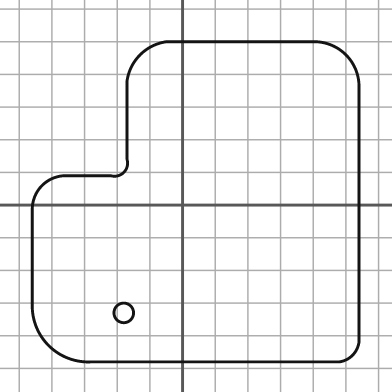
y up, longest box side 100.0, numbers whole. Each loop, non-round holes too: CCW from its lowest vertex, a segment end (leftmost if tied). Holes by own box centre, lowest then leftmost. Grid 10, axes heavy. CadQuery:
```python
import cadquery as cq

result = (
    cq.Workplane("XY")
    .moveTo(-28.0, -48.0)
    .lineTo(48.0, -48.0)
    .threePointArc((52.0, -46.0), (54.0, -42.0))
    .lineTo(54.0, 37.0)
    .threePointArc((50.0, 46.0), (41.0, 50.0))
    .lineTo(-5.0, 50.0)
    .threePointArc((-13.0, 46.0), (-17.0, 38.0))
    .lineTo(-17.0, 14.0)
    .threePointArc((-18.0, 10.0), (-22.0, 9.0))
    .lineTo(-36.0, 9.0)
    .threePointArc((-43.0, 6.0), (-46.0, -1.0))
    .lineTo(-46.0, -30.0)
    .threePointArc((-41.0, -43.0), (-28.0, -48.0))
    .close()
    .moveTo(-18.0, -33.0)
    .circle(3.0)
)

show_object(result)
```